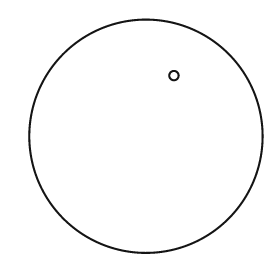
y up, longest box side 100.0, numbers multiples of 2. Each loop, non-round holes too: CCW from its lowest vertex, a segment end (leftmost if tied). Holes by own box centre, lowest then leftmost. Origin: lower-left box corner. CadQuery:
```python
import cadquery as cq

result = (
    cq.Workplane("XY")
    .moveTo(50.0, 50.0)
    .circle(50.0)
    .moveTo(62.0, 76.0)
    .circle(2.0)
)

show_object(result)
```